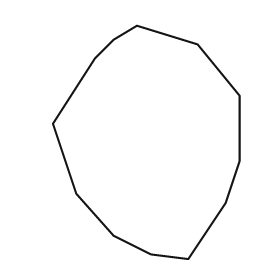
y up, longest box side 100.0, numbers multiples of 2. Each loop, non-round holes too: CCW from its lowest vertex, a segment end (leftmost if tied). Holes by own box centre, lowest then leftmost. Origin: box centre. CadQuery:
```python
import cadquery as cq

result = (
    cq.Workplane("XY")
    .moveTo(18.0, -50.0)
    .lineTo(34.0, -26.0)
    .lineTo(40.0, -8.0)
    .lineTo(40.0, 20.0)
    .lineTo(22.0, 42.0)
    .lineTo(-4.0, 50.0)
    .lineTo(-14.0, 44.0)
    .lineTo(-22.0, 36.0)
    .lineTo(-40.0, 8.0)
    .lineTo(-30.0, -22.0)
    .lineTo(-14.0, -40.0)
    .lineTo(2.0, -48.0)
    .close()
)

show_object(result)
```